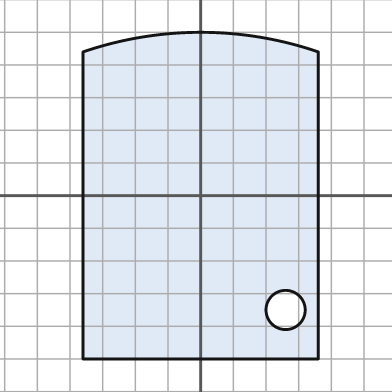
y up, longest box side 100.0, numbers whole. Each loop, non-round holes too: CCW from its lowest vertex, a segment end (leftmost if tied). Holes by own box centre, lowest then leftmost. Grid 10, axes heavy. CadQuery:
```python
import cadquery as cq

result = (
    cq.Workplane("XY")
    .moveTo(-36.0, -50.0)
    .lineTo(36.0, -50.0)
    .lineTo(36.0, 44.0)
    .threePointArc((0.0, 50.0), (-36.0, 44.0))
    .close()
    .moveTo(26.0, -35.0)
    .circle(6.0)
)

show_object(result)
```